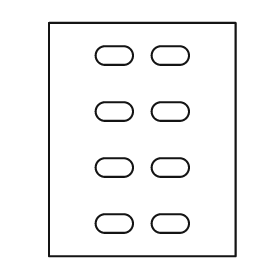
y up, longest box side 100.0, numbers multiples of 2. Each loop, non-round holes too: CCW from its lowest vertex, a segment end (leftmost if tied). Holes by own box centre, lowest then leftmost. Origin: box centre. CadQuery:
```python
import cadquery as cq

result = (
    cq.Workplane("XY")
    .moveTo(-40.0, -50.0)
    .lineTo(40.0, -50.0)
    .lineTo(40.0, 50.0)
    .lineTo(-40.0, 50.0)
    .close()
    .moveTo(-16.0, -40.0)
    .lineTo(-8.0, -40.0)
    .threePointArc((-4.0, -36.0), (-8.0, -32.0))
    .lineTo(-16.0, -32.0)
    .threePointArc((-20.0, -36.0), (-16.0, -40.0))
    .close()
    .moveTo(8.0, -40.0)
    .lineTo(16.0, -40.0)
    .threePointArc((20.0, -36.0), (16.0, -32.0))
    .lineTo(8.0, -32.0)
    .threePointArc((4.0, -36.0), (8.0, -40.0))
    .close()
    .moveTo(-16.0, -16.0)
    .lineTo(-8.0, -16.0)
    .threePointArc((-4.0, -12.0), (-8.0, -8.0))
    .lineTo(-16.0, -8.0)
    .threePointArc((-20.0, -12.0), (-16.0, -16.0))
    .close()
    .moveTo(8.0, -16.0)
    .lineTo(16.0, -16.0)
    .threePointArc((20.0, -12.0), (16.0, -8.0))
    .lineTo(8.0, -8.0)
    .threePointArc((4.0, -12.0), (8.0, -16.0))
    .close()
    .moveTo(-16.0, 8.0)
    .lineTo(-8.0, 8.0)
    .threePointArc((-4.0, 12.0), (-8.0, 16.0))
    .lineTo(-16.0, 16.0)
    .threePointArc((-20.0, 12.0), (-16.0, 8.0))
    .close()
    .moveTo(8.0, 8.0)
    .lineTo(16.0, 8.0)
    .threePointArc((20.0, 12.0), (16.0, 16.0))
    .lineTo(8.0, 16.0)
    .threePointArc((4.0, 12.0), (8.0, 8.0))
    .close()
    .moveTo(-16.0, 32.0)
    .lineTo(-8.0, 32.0)
    .threePointArc((-4.0, 36.0), (-8.0, 40.0))
    .lineTo(-16.0, 40.0)
    .threePointArc((-20.0, 36.0), (-16.0, 32.0))
    .close()
    .moveTo(8.0, 32.0)
    .lineTo(16.0, 32.0)
    .threePointArc((20.0, 36.0), (16.0, 40.0))
    .lineTo(8.0, 40.0)
    .threePointArc((4.0, 36.0), (8.0, 32.0))
    .close()
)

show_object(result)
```